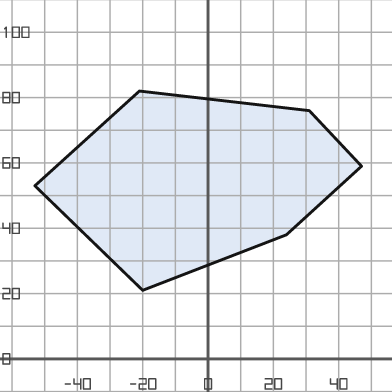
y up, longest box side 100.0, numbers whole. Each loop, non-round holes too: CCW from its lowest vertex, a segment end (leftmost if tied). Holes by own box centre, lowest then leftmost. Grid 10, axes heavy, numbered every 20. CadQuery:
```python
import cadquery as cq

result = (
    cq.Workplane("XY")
    .moveTo(-20.0, 21.0)
    .lineTo(24.0, 38.0)
    .lineTo(47.0, 59.0)
    .lineTo(31.0, 76.0)
    .lineTo(-21.0, 82.0)
    .lineTo(-53.0, 53.0)
    .close()
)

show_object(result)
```